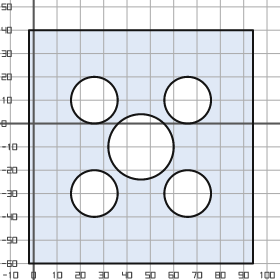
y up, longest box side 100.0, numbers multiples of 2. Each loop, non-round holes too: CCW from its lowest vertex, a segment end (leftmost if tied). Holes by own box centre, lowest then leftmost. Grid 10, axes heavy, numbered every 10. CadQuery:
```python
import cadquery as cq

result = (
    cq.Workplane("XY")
    .moveTo(-2.0, -60.0)
    .lineTo(94.0, -60.0)
    .lineTo(94.0, 40.0)
    .lineTo(-2.0, 40.0)
    .close()
    .moveTo(26.0, -30.0)
    .circle(10.0)
    .moveTo(66.0, -30.0)
    .circle(10.0)
    .moveTo(46.0, -10.0)
    .circle(14.0)
    .moveTo(26.0, 10.0)
    .circle(10.0)
    .moveTo(66.0, 10.0)
    .circle(10.0)
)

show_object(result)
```